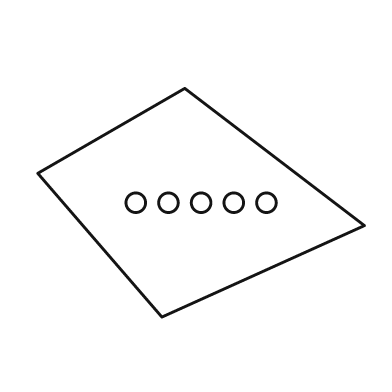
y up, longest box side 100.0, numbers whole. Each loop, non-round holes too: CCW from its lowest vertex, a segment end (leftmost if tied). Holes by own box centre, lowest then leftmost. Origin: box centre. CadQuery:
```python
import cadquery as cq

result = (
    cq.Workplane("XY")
    .moveTo(-12.0, -35.0)
    .lineTo(50.0, -7.0)
    .lineTo(-5.0, 35.0)
    .lineTo(-50.0, 9.0)
    .close()
    .moveTo(-20.0, 0.0)
    .circle(3.0)
    .moveTo(-10.0, 0.0)
    .circle(3.0)
    .moveTo(0.0, 0.0)
    .circle(3.0)
    .moveTo(10.0, 0.0)
    .circle(3.0)
    .moveTo(20.0, 0.0)
    .circle(3.0)
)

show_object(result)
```